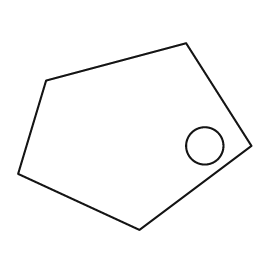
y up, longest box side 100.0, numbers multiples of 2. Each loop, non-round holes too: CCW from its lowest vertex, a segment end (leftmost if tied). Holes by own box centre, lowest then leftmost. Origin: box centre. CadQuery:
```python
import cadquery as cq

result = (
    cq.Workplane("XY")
    .moveTo(2.0, -40.0)
    .lineTo(50.0, -4.0)
    .lineTo(22.0, 40.0)
    .lineTo(-38.0, 24.0)
    .lineTo(-50.0, -16.0)
    .close()
    .moveTo(30.0, -4.0)
    .circle(8.0)
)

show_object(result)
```